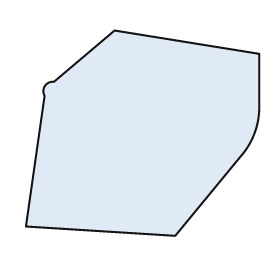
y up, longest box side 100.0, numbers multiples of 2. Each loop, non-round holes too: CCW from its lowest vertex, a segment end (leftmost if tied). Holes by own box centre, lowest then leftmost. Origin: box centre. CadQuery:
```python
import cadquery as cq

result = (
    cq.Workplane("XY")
    .moveTo(14.0, -44.0)
    .lineTo(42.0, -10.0)
    .threePointArc((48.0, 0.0), (50.0, 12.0))
    .lineTo(50.0, 34.0)
    .lineTo(-12.0, 44.0)
    .lineTo(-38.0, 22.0)
    .threePointArc((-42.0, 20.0), (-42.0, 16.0))
    .lineTo(-50.0, -40.0)
    .close()
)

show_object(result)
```